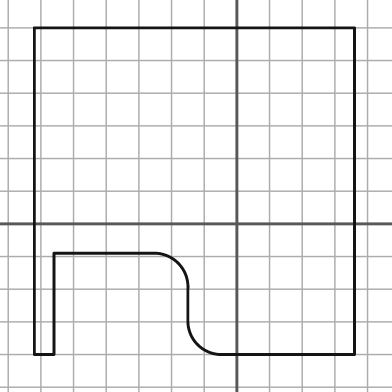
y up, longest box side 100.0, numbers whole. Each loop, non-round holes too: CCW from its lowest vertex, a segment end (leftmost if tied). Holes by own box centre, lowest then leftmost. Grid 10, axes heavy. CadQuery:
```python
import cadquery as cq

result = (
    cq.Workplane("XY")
    .moveTo(-62.0, -40.0)
    .lineTo(-56.0, -40.0)
    .lineTo(-56.0, -9.0)
    .lineTo(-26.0, -9.0)
    .threePointArc((-18.0, -12.0), (-15.0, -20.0))
    .lineTo(-15.0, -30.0)
    .threePointArc((-12.0, -37.0), (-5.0, -40.0))
    .lineTo(36.0, -40.0)
    .lineTo(36.0, 60.0)
    .lineTo(-62.0, 60.0)
    .close()
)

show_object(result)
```